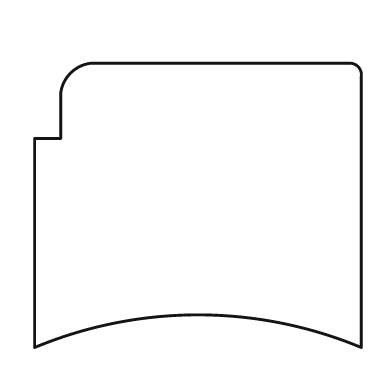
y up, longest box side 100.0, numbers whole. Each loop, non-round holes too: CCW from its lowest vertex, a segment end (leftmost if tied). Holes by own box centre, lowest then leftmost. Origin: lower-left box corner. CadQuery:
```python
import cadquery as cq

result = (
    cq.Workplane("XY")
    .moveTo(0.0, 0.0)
    .threePointArc((50.0, 10.0), (100.0, 0.0))
    .lineTo(100.0, 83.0)
    .threePointArc((99.0, 86.0), (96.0, 87.0))
    .lineTo(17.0, 87.0)
    .threePointArc((11.0, 84.0), (8.0, 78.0))
    .lineTo(8.0, 64.0)
    .lineTo(0.0, 64.0)
    .close()
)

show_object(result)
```